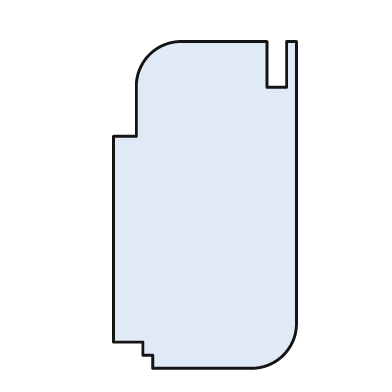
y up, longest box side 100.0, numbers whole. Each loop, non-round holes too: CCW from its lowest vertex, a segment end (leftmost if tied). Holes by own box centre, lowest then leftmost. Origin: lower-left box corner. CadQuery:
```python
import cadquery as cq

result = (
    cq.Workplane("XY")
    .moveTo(12.0, 0.0)
    .lineTo(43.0, 0.0)
    .threePointArc((52.0, 4.0), (56.0, 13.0))
    .lineTo(56.0, 100.0)
    .lineTo(53.0, 100.0)
    .lineTo(53.0, 86.0)
    .lineTo(47.0, 86.0)
    .lineTo(47.0, 100.0)
    .lineTo(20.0, 100.0)
    .threePointArc((11.0, 96.0), (7.0, 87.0))
    .lineTo(7.0, 71.0)
    .lineTo(0.0, 71.0)
    .lineTo(0.0, 8.0)
    .lineTo(9.0, 8.0)
    .lineTo(9.0, 4.0)
    .lineTo(12.0, 4.0)
    .close()
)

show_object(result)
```